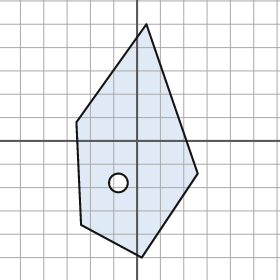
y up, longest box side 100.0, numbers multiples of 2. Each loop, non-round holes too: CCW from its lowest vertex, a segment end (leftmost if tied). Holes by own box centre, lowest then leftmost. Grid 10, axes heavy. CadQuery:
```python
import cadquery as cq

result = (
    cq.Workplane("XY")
    .moveTo(2.0, -50.0)
    .lineTo(26.0, -14.0)
    .lineTo(4.0, 50.0)
    .lineTo(-26.0, 8.0)
    .lineTo(-24.0, -36.0)
    .close()
    .moveTo(-8.0, -18.0)
    .circle(4.0)
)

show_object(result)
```